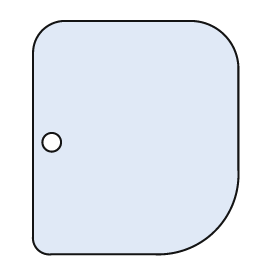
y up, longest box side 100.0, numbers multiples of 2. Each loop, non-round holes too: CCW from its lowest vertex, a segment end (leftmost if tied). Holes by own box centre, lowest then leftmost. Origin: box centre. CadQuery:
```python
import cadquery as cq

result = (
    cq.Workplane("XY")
    .moveTo(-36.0, -50.0)
    .lineTo(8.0, -50.0)
    .threePointArc((34.0, -40.0), (44.0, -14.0))
    .lineTo(44.0, 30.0)
    .threePointArc((38.0, 44.0), (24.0, 50.0))
    .lineTo(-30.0, 50.0)
    .threePointArc((-40.0, 46.0), (-44.0, 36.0))
    .lineTo(-44.0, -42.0)
    .threePointArc((-42.0, -48.0), (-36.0, -50.0))
    .close()
    .moveTo(-36.0, -2.0)
    .circle(4.0)
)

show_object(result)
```